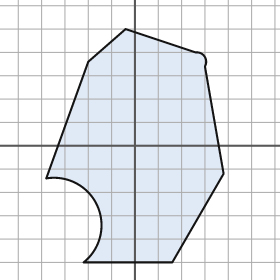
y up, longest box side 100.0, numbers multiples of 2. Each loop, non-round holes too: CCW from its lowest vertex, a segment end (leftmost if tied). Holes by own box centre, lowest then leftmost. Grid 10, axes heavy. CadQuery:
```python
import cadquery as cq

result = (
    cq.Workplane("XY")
    .moveTo(-22.0, -50.0)
    .lineTo(16.0, -50.0)
    .lineTo(38.0, -12.0)
    .lineTo(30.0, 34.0)
    .threePointArc((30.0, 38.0), (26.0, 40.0))
    .lineTo(-4.0, 50.0)
    .lineTo(-20.0, 36.0)
    .lineTo(-38.0, -14.0)
    .threePointArc((-16.0, -26.0), (-22.0, -50.0))
    .close()
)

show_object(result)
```